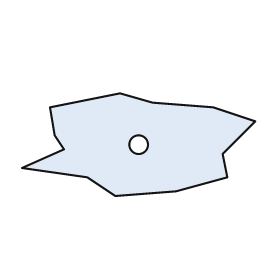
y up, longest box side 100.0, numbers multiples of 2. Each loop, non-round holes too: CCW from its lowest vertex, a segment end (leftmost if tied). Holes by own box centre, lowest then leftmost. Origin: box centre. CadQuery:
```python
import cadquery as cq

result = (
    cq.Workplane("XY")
    .moveTo(-10.0, -22.0)
    .lineTo(16.0, -20.0)
    .lineTo(38.0, -14.0)
    .lineTo(36.0, -4.0)
    .lineTo(50.0, 10.0)
    .lineTo(32.0, 16.0)
    .lineTo(6.0, 18.0)
    .lineTo(-8.0, 22.0)
    .lineTo(-38.0, 16.0)
    .lineTo(-36.0, 4.0)
    .lineTo(-32.0, -2.0)
    .lineTo(-50.0, -10.0)
    .lineTo(-22.0, -14.0)
    .close()
    .moveTo(0.0, 0.0)
    .circle(4.0)
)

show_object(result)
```